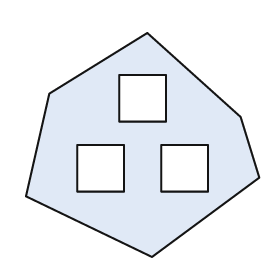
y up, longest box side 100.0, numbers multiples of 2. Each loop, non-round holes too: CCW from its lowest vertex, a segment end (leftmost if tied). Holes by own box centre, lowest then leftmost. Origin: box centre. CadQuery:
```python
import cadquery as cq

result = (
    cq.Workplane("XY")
    .moveTo(4.0, -48.0)
    .lineTo(50.0, -14.0)
    .lineTo(42.0, 12.0)
    .lineTo(2.0, 48.0)
    .lineTo(-40.0, 22.0)
    .lineTo(-50.0, -22.0)
    .close()
    .moveTo(-28.0, -20.0)
    .lineTo(-8.0, -20.0)
    .lineTo(-8.0, 0.0)
    .lineTo(-28.0, 0.0)
    .close()
    .moveTo(8.0, -20.0)
    .lineTo(28.0, -20.0)
    .lineTo(28.0, 0.0)
    .lineTo(8.0, 0.0)
    .close()
    .moveTo(-10.0, 10.0)
    .lineTo(10.0, 10.0)
    .lineTo(10.0, 30.0)
    .lineTo(-10.0, 30.0)
    .close()
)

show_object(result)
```